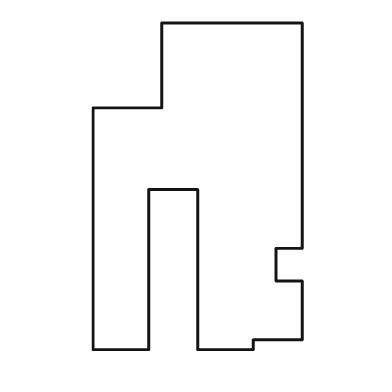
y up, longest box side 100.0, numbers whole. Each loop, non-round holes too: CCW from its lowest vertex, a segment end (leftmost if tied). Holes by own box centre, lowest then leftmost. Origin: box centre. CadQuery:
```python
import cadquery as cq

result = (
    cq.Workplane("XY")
    .moveTo(-32.0, -50.0)
    .lineTo(-15.0, -50.0)
    .lineTo(-15.0, -1.0)
    .lineTo(0.0, -1.0)
    .lineTo(0.0, -50.0)
    .lineTo(17.0, -50.0)
    .lineTo(17.0, -47.0)
    .lineTo(32.0, -47.0)
    .lineTo(32.0, -29.0)
    .lineTo(24.0, -29.0)
    .lineTo(24.0, -19.0)
    .lineTo(32.0, -19.0)
    .lineTo(32.0, 50.0)
    .lineTo(-11.0, 50.0)
    .lineTo(-11.0, 24.0)
    .lineTo(-32.0, 24.0)
    .close()
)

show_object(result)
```